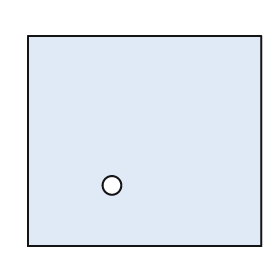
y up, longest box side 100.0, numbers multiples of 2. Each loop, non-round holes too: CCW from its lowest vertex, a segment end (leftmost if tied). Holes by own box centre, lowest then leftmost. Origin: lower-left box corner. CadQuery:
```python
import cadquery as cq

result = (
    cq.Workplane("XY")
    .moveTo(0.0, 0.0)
    .lineTo(100.0, 0.0)
    .lineTo(100.0, 90.0)
    .lineTo(0.0, 90.0)
    .close()
    .moveTo(36.0, 26.0)
    .circle(4.0)
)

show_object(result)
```